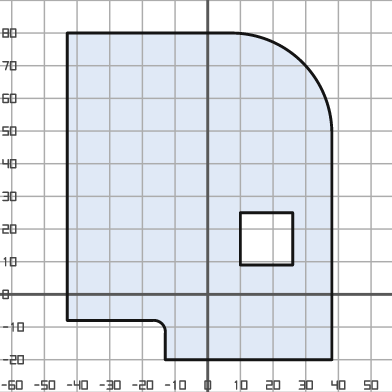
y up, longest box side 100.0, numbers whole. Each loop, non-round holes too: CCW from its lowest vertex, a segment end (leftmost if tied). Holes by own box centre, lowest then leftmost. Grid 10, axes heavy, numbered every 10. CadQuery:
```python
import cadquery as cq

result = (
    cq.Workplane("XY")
    .moveTo(-13.0, -20.0)
    .lineTo(38.0, -20.0)
    .lineTo(38.0, 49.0)
    .threePointArc((29.0, 71.0), (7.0, 80.0))
    .lineTo(-43.0, 80.0)
    .lineTo(-43.0, -8.0)
    .lineTo(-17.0, -8.0)
    .threePointArc((-14.0, -9.0), (-13.0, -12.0))
    .close()
    .moveTo(10.0, 9.0)
    .lineTo(26.0, 9.0)
    .lineTo(26.0, 25.0)
    .lineTo(10.0, 25.0)
    .close()
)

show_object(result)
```